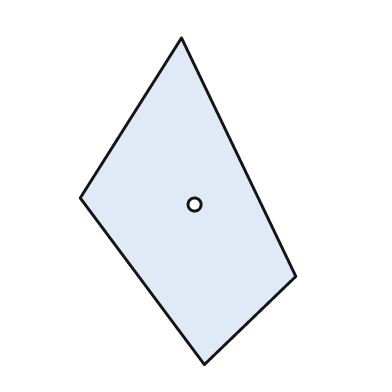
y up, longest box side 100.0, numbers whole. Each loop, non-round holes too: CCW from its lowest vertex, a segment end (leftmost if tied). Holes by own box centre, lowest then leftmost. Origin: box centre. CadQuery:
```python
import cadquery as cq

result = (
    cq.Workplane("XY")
    .moveTo(5.0, -50.0)
    .lineTo(33.0, -23.0)
    .lineTo(-2.0, 50.0)
    .lineTo(-33.0, 1.0)
    .close()
    .moveTo(2.0, -1.0)
    .circle(2.0)
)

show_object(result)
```